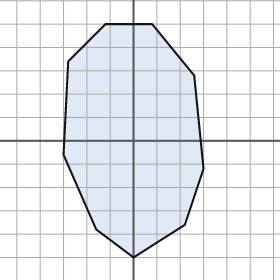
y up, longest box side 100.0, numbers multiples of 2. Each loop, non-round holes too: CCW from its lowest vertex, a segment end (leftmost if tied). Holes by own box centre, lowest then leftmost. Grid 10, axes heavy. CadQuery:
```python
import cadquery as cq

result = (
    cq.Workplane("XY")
    .moveTo(0.0, -50.0)
    .lineTo(22.0, -36.0)
    .lineTo(30.0, -12.0)
    .lineTo(26.0, 28.0)
    .lineTo(8.0, 50.0)
    .lineTo(-12.0, 50.0)
    .lineTo(-28.0, 34.0)
    .lineTo(-30.0, -6.0)
    .lineTo(-16.0, -38.0)
    .close()
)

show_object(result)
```